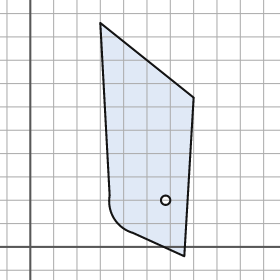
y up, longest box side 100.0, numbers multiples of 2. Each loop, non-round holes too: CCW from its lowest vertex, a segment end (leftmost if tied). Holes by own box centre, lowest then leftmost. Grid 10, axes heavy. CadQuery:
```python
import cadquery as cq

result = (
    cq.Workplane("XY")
    .moveTo(66.0, -4.0)
    .lineTo(70.0, 64.0)
    .lineTo(30.0, 96.0)
    .lineTo(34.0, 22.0)
    .threePointArc((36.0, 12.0), (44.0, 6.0))
    .close()
    .moveTo(58.0, 20.0)
    .circle(2.0)
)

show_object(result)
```